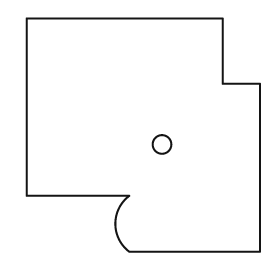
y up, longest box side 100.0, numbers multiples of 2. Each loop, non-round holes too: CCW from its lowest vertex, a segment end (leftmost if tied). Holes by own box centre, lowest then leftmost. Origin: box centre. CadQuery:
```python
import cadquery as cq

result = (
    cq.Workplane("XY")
    .moveTo(-6.0, -50.0)
    .lineTo(50.0, -50.0)
    .lineTo(50.0, 22.0)
    .lineTo(34.0, 22.0)
    .lineTo(34.0, 50.0)
    .lineTo(-50.0, 50.0)
    .lineTo(-50.0, -26.0)
    .lineTo(-6.0, -26.0)
    .threePointArc((-12.0, -38.0), (-6.0, -50.0))
    .close()
    .moveTo(8.0, -4.0)
    .circle(4.0)
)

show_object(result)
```